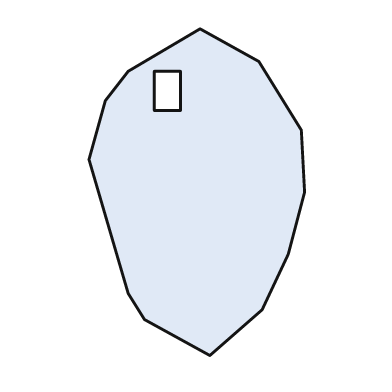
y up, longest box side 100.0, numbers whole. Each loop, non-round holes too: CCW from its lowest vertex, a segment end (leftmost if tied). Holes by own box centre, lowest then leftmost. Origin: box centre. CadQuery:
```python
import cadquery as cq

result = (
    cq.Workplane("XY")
    .moveTo(4.0, -50.0)
    .lineTo(20.0, -36.0)
    .lineTo(28.0, -19.0)
    .lineTo(33.0, 0.0)
    .lineTo(32.0, 19.0)
    .lineTo(19.0, 40.0)
    .lineTo(1.0, 50.0)
    .lineTo(-21.0, 37.0)
    .lineTo(-28.0, 28.0)
    .lineTo(-33.0, 10.0)
    .lineTo(-21.0, -31.0)
    .lineTo(-16.0, -39.0)
    .close()
    .moveTo(-13.0, 25.0)
    .lineTo(-5.0, 25.0)
    .lineTo(-5.0, 37.0)
    .lineTo(-13.0, 37.0)
    .close()
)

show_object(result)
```